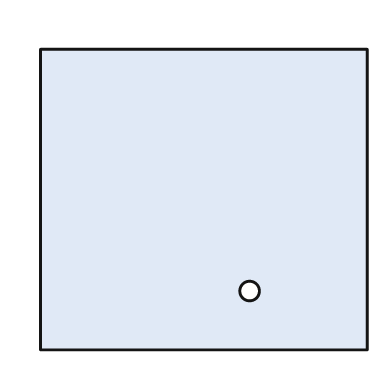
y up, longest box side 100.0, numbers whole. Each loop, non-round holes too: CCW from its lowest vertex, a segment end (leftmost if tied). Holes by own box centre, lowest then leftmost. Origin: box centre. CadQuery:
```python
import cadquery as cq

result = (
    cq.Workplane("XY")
    .moveTo(-50.0, -46.0)
    .lineTo(50.0, -46.0)
    .lineTo(50.0, 46.0)
    .lineTo(-50.0, 46.0)
    .close()
    .moveTo(14.0, -28.0)
    .circle(3.0)
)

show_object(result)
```